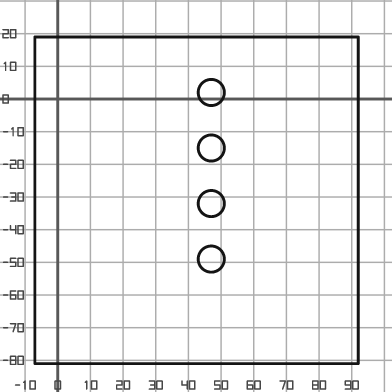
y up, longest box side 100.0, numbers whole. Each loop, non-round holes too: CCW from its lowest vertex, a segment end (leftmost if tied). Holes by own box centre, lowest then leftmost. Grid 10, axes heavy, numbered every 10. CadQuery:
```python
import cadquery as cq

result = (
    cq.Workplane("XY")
    .moveTo(-7.0, -81.0)
    .lineTo(92.0, -81.0)
    .lineTo(92.0, 19.0)
    .lineTo(-7.0, 19.0)
    .close()
    .moveTo(47.0, -49.0)
    .circle(4.0)
    .moveTo(47.0, -32.0)
    .circle(4.0)
    .moveTo(47.0, -15.0)
    .circle(4.0)
    .moveTo(47.0, 2.0)
    .circle(4.0)
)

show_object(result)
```